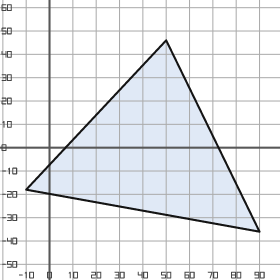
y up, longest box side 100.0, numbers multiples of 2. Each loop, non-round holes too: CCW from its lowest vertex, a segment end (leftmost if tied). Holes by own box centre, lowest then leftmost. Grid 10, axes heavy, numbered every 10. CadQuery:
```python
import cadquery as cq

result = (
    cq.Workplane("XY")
    .moveTo(90.0, -36.0)
    .lineTo(50.0, 46.0)
    .lineTo(-10.0, -18.0)
    .close()
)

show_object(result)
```